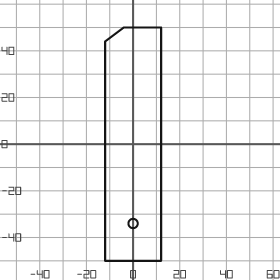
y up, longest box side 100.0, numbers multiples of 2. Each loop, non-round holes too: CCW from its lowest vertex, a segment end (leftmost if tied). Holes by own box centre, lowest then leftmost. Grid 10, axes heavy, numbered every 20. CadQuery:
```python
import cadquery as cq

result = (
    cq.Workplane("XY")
    .moveTo(-12.0, -50.0)
    .lineTo(12.0, -50.0)
    .lineTo(12.0, 50.0)
    .lineTo(-4.0, 50.0)
    .lineTo(-12.0, 44.0)
    .close()
    .moveTo(0.0, -34.0)
    .circle(2.0)
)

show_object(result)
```